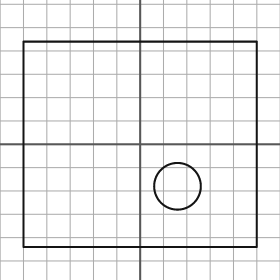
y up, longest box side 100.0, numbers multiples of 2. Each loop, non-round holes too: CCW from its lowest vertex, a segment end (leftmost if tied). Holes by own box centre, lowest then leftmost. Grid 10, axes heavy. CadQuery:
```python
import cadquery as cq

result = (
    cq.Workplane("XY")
    .moveTo(-50.0, -44.0)
    .lineTo(50.0, -44.0)
    .lineTo(50.0, 44.0)
    .lineTo(-50.0, 44.0)
    .close()
    .moveTo(16.0, -18.0)
    .circle(10.0)
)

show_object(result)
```